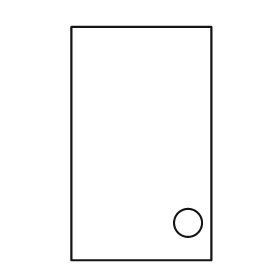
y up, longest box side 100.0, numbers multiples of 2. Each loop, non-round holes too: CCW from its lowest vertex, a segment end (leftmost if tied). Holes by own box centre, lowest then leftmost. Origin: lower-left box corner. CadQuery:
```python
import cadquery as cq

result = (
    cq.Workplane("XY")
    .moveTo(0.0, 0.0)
    .lineTo(60.0, 0.0)
    .lineTo(60.0, 100.0)
    .lineTo(0.0, 100.0)
    .close()
    .moveTo(50.0, 16.0)
    .circle(6.0)
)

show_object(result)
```